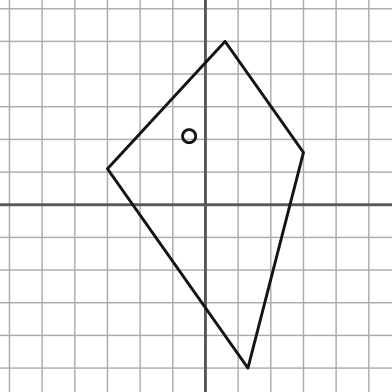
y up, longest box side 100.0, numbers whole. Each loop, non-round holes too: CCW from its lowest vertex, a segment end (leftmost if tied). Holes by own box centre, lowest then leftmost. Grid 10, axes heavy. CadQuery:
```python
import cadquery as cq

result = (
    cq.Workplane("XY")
    .moveTo(13.0, -50.0)
    .lineTo(30.0, 16.0)
    .lineTo(6.0, 50.0)
    .lineTo(-30.0, 11.0)
    .close()
    .moveTo(-5.0, 21.0)
    .circle(2.0)
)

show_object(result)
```